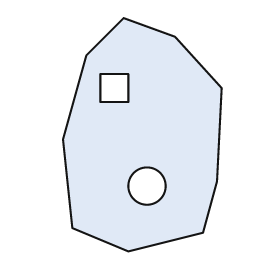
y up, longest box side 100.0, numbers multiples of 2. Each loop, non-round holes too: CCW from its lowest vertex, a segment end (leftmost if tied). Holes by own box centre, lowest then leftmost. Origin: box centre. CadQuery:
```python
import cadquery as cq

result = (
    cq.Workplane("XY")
    .moveTo(-6.0, -50.0)
    .lineTo(26.0, -42.0)
    .lineTo(32.0, -20.0)
    .lineTo(34.0, 20.0)
    .lineTo(14.0, 42.0)
    .lineTo(-8.0, 50.0)
    .lineTo(-24.0, 34.0)
    .lineTo(-34.0, -2.0)
    .lineTo(-30.0, -40.0)
    .close()
    .moveTo(2.0, -22.0)
    .circle(8.0)
    .moveTo(-18.0, 14.0)
    .lineTo(-6.0, 14.0)
    .lineTo(-6.0, 26.0)
    .lineTo(-18.0, 26.0)
    .close()
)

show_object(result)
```